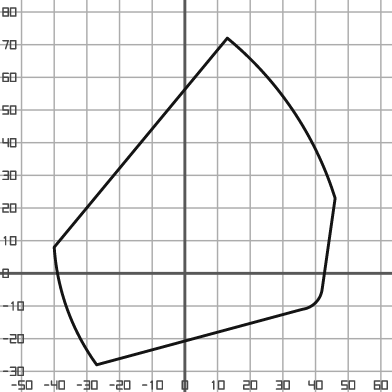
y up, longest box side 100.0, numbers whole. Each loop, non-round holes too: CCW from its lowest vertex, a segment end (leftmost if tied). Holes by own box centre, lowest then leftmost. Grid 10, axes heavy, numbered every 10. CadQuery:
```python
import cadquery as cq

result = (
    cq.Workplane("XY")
    .moveTo(-27.0, -28.0)
    .lineTo(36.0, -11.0)
    .threePointArc((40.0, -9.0), (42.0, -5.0))
    .lineTo(46.0, 23.0)
    .threePointArc((33.0, 50.0), (13.0, 72.0))
    .lineTo(-40.0, 8.0)
    .threePointArc((-36.0, -11.0), (-27.0, -28.0))
    .close()
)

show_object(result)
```